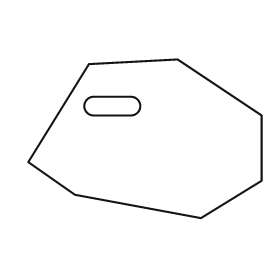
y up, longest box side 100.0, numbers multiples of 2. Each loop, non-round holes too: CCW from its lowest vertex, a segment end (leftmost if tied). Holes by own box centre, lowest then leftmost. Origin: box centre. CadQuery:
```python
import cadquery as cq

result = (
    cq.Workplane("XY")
    .moveTo(24.0, -34.0)
    .lineTo(50.0, -18.0)
    .lineTo(50.0, 10.0)
    .lineTo(14.0, 34.0)
    .lineTo(-24.0, 32.0)
    .lineTo(-50.0, -10.0)
    .lineTo(-30.0, -24.0)
    .close()
    .moveTo(-22.0, 10.0)
    .lineTo(-6.0, 10.0)
    .threePointArc((-2.0, 14.0), (-6.0, 18.0))
    .lineTo(-22.0, 18.0)
    .threePointArc((-26.0, 14.0), (-22.0, 10.0))
    .close()
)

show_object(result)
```